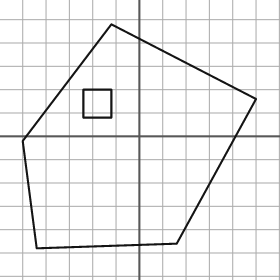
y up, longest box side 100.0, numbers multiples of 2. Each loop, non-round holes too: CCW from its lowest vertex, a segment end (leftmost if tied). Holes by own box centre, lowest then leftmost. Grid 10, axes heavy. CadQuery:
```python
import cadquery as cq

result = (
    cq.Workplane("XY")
    .moveTo(-44.0, -48.0)
    .lineTo(16.0, -46.0)
    .lineTo(50.0, 16.0)
    .lineTo(-12.0, 48.0)
    .lineTo(-50.0, -2.0)
    .close()
    .moveTo(-24.0, 8.0)
    .lineTo(-12.0, 8.0)
    .lineTo(-12.0, 20.0)
    .lineTo(-24.0, 20.0)
    .close()
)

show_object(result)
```